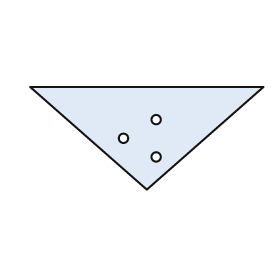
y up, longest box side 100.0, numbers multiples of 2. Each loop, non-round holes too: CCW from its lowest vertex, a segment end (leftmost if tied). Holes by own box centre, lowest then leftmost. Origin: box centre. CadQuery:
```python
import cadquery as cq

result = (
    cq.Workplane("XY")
    .moveTo(0.0, -22.0)
    .lineTo(50.0, 22.0)
    .lineTo(-50.0, 22.0)
    .close()
    .moveTo(4.0, -8.0)
    .circle(2.0)
    .moveTo(-10.0, 0.0)
    .circle(2.0)
    .moveTo(4.0, 8.0)
    .circle(2.0)
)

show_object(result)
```